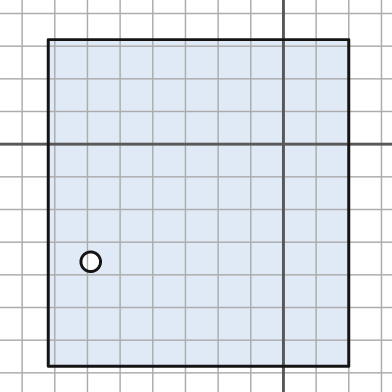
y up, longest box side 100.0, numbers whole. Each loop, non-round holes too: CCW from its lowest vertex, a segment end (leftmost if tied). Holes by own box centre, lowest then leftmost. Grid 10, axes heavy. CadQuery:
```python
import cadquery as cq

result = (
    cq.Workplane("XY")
    .moveTo(-72.0, -68.0)
    .lineTo(20.0, -68.0)
    .lineTo(20.0, 32.0)
    .lineTo(-72.0, 32.0)
    .close()
    .moveTo(-59.0, -36.0)
    .circle(3.0)
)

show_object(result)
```